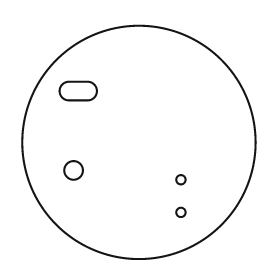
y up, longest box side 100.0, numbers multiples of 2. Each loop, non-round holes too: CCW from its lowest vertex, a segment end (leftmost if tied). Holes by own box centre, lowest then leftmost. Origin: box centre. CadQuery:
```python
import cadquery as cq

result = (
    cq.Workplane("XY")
    .moveTo(0.0, 0.0)
    .circle(50.0)
    .moveTo(18.0, -30.0)
    .circle(2.0)
    .moveTo(18.0, -16.0)
    .circle(2.0)
    .moveTo(-28.0, -12.0)
    .circle(4.0)
    .moveTo(-30.0, 18.0)
    .lineTo(-22.0, 18.0)
    .threePointArc((-18.0, 22.0), (-22.0, 26.0))
    .lineTo(-30.0, 26.0)
    .threePointArc((-34.0, 22.0), (-30.0, 18.0))
    .close()
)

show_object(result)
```